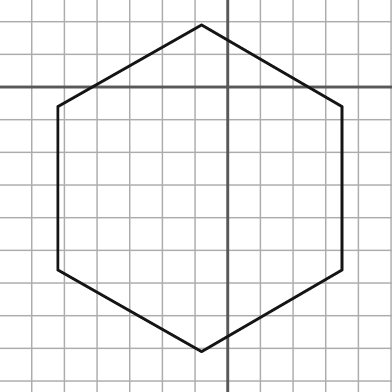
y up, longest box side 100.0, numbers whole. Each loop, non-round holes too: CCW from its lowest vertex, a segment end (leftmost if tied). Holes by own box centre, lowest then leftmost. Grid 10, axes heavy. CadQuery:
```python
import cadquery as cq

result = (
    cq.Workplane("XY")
    .moveTo(-8.0, -81.0)
    .lineTo(35.0, -56.0)
    .lineTo(35.0, -6.0)
    .lineTo(-8.0, 19.0)
    .lineTo(-52.0, -6.0)
    .lineTo(-52.0, -56.0)
    .close()
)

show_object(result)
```